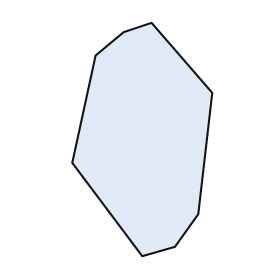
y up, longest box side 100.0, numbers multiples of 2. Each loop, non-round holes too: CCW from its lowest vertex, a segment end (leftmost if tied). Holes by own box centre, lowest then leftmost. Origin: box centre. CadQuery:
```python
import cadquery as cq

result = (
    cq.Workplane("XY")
    .moveTo(0.0, -50.0)
    .lineTo(14.0, -46.0)
    .lineTo(24.0, -32.0)
    .lineTo(30.0, 20.0)
    .lineTo(4.0, 50.0)
    .lineTo(-8.0, 46.0)
    .lineTo(-20.0, 36.0)
    .lineTo(-30.0, -10.0)
    .close()
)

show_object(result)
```